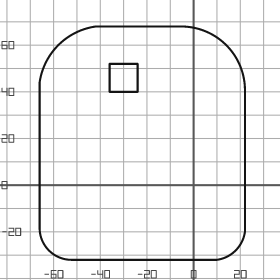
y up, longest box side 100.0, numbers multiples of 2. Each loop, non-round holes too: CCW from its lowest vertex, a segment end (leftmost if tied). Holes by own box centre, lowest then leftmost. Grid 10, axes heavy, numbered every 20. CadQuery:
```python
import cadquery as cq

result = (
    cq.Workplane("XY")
    .moveTo(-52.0, -32.0)
    .lineTo(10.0, -32.0)
    .threePointArc((18.0, -28.0), (22.0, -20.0))
    .lineTo(22.0, 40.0)
    .threePointArc((14.0, 60.0), (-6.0, 68.0))
    .lineTo(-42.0, 68.0)
    .threePointArc((-58.0, 60.0), (-66.0, 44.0))
    .lineTo(-66.0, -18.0)
    .threePointArc((-62.0, -28.0), (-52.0, -32.0))
    .close()
    .moveTo(-36.0, 40.0)
    .lineTo(-24.0, 40.0)
    .lineTo(-24.0, 52.0)
    .lineTo(-36.0, 52.0)
    .close()
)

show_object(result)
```